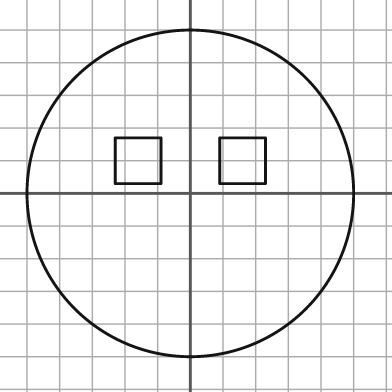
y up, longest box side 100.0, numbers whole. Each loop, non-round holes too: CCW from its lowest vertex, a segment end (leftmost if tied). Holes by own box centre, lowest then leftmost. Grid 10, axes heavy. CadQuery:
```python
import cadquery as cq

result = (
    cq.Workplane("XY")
    .moveTo(0.0, 0.0)
    .circle(50.0)
    .moveTo(-23.0, 3.0)
    .lineTo(-9.0, 3.0)
    .lineTo(-9.0, 17.0)
    .lineTo(-23.0, 17.0)
    .close()
    .moveTo(9.0, 3.0)
    .lineTo(23.0, 3.0)
    .lineTo(23.0, 17.0)
    .lineTo(9.0, 17.0)
    .close()
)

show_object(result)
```